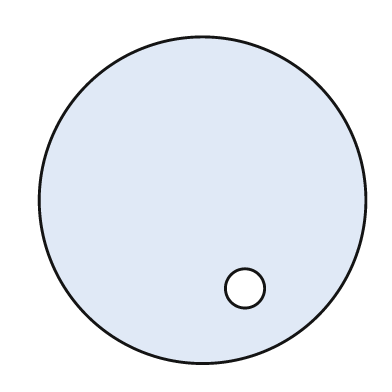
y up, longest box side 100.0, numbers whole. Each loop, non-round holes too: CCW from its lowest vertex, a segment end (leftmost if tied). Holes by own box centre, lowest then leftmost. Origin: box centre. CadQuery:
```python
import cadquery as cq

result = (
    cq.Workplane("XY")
    .moveTo(0.0, 0.0)
    .circle(50.0)
    .moveTo(13.0, -27.0)
    .circle(6.0)
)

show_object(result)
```